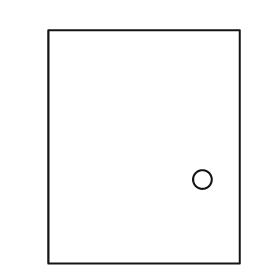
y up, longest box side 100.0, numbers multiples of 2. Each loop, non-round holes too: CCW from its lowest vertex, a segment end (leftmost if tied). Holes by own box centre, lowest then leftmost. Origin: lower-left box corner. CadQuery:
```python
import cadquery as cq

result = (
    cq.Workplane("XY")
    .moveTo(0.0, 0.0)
    .lineTo(82.0, 0.0)
    .lineTo(82.0, 100.0)
    .lineTo(0.0, 100.0)
    .close()
    .moveTo(66.0, 36.0)
    .circle(4.0)
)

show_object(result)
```